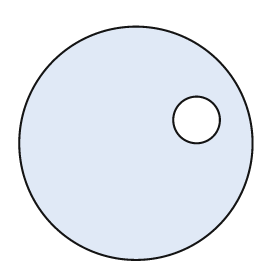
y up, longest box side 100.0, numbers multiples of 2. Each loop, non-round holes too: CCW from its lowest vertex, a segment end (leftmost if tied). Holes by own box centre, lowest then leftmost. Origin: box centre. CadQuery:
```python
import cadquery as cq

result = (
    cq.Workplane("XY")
    .moveTo(0.0, 0.0)
    .circle(50.0)
    .moveTo(26.0, 10.0)
    .circle(10.0)
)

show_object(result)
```